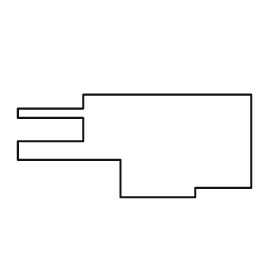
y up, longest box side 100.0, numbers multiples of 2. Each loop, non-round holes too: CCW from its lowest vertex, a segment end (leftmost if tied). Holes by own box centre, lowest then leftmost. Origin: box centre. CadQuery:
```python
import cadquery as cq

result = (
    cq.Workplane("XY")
    .moveTo(-6.0, -22.0)
    .lineTo(26.0, -22.0)
    .lineTo(26.0, -18.0)
    .lineTo(50.0, -18.0)
    .lineTo(50.0, 22.0)
    .lineTo(-22.0, 22.0)
    .lineTo(-22.0, 16.0)
    .lineTo(-50.0, 16.0)
    .lineTo(-50.0, 12.0)
    .lineTo(-22.0, 12.0)
    .lineTo(-22.0, 2.0)
    .lineTo(-50.0, 2.0)
    .lineTo(-50.0, -6.0)
    .lineTo(-6.0, -6.0)
    .close()
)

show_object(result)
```